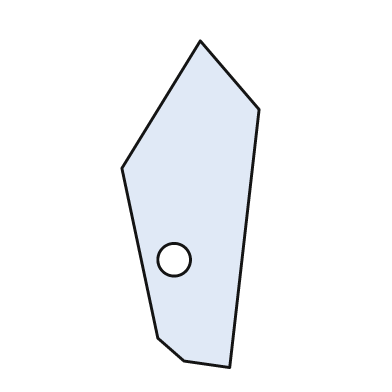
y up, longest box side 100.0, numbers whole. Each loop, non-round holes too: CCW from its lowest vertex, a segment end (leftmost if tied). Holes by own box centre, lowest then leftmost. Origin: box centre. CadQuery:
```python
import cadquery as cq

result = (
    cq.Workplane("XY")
    .moveTo(12.0, -50.0)
    .lineTo(21.0, 29.0)
    .lineTo(3.0, 50.0)
    .lineTo(-21.0, 11.0)
    .lineTo(-10.0, -41.0)
    .lineTo(-2.0, -48.0)
    .close()
    .moveTo(-5.0, -17.0)
    .circle(5.0)
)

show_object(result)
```